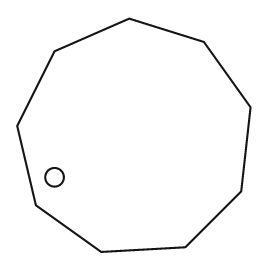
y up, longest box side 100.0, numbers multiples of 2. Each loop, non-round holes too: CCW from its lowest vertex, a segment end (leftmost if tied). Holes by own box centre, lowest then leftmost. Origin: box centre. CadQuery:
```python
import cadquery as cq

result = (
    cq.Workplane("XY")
    .moveTo(-14.0, -50.0)
    .lineTo(22.0, -48.0)
    .lineTo(46.0, -24.0)
    .lineTo(50.0, 12.0)
    .lineTo(30.0, 40.0)
    .lineTo(-2.0, 50.0)
    .lineTo(-34.0, 36.0)
    .lineTo(-50.0, 4.0)
    .lineTo(-42.0, -30.0)
    .close()
    .moveTo(-34.0, -18.0)
    .circle(4.0)
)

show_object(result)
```